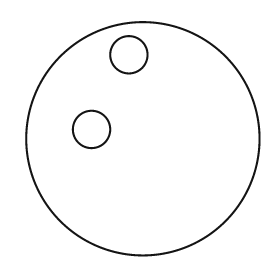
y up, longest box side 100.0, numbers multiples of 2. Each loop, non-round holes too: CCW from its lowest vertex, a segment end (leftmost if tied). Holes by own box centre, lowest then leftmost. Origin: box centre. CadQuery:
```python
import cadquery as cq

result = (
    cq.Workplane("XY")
    .moveTo(0.0, 0.0)
    .circle(50.0)
    .moveTo(-22.0, 4.0)
    .circle(8.0)
    .moveTo(-6.0, 36.0)
    .circle(8.0)
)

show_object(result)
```